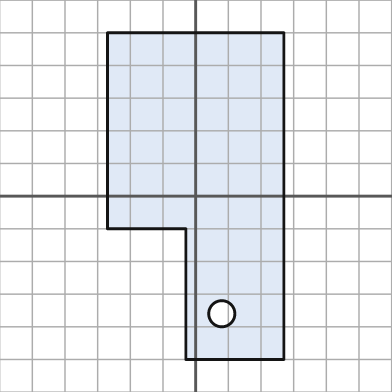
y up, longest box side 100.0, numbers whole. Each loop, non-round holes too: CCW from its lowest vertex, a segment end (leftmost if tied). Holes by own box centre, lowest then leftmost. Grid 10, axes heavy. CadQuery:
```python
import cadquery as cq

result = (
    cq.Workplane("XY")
    .moveTo(-3.0, -50.0)
    .lineTo(27.0, -50.0)
    .lineTo(27.0, 50.0)
    .lineTo(-27.0, 50.0)
    .lineTo(-27.0, -10.0)
    .lineTo(-3.0, -10.0)
    .close()
    .moveTo(8.0, -36.0)
    .circle(4.0)
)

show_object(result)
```